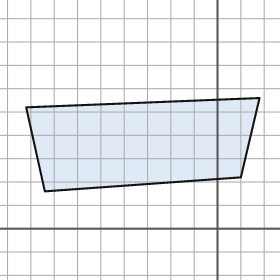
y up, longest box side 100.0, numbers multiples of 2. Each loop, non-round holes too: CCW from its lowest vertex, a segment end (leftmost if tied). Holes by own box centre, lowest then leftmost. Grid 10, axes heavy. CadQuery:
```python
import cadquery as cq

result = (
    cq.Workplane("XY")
    .moveTo(-74.0, 16.0)
    .lineTo(10.0, 22.0)
    .lineTo(18.0, 56.0)
    .lineTo(-82.0, 52.0)
    .close()
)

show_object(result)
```